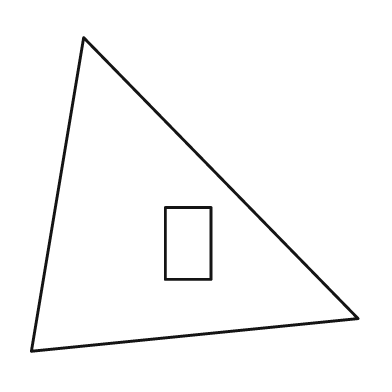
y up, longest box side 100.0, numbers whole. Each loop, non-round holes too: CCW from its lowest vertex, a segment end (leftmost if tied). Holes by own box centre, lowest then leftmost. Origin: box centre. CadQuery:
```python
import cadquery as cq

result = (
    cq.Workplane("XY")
    .moveTo(-50.0, -48.0)
    .lineTo(50.0, -38.0)
    .lineTo(-34.0, 48.0)
    .close()
    .moveTo(-9.0, -26.0)
    .lineTo(5.0, -26.0)
    .lineTo(5.0, -4.0)
    .lineTo(-9.0, -4.0)
    .close()
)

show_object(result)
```